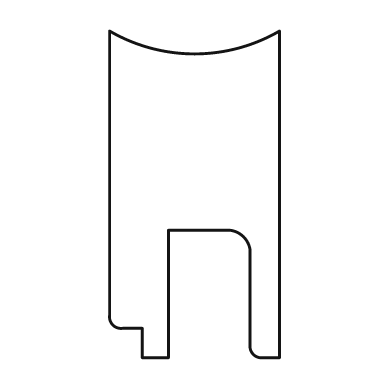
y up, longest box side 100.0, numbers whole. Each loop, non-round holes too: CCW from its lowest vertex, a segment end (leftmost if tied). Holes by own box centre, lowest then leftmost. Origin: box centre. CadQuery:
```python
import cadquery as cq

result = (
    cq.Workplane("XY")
    .moveTo(-16.0, -50.0)
    .lineTo(-8.0, -50.0)
    .lineTo(-8.0, -11.0)
    .lineTo(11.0, -11.0)
    .threePointArc((15.0, -13.0), (17.0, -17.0))
    .lineTo(17.0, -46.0)
    .threePointArc((18.0, -49.0), (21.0, -50.0))
    .lineTo(26.0, -50.0)
    .lineTo(26.0, 50.0)
    .threePointArc((0.0, 43.0), (-26.0, 50.0))
    .lineTo(-26.0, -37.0)
    .threePointArc((-25.0, -40.0), (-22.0, -41.0))
    .lineTo(-16.0, -41.0)
    .close()
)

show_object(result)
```